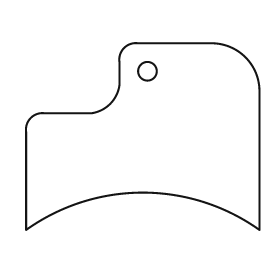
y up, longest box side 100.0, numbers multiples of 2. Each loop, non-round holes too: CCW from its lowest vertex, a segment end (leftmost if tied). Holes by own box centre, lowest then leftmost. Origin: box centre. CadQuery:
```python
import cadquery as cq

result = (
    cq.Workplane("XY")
    .moveTo(-50.0, -40.0)
    .threePointArc((0.0, -24.0), (50.0, -40.0))
    .lineTo(50.0, 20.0)
    .threePointArc((44.0, 34.0), (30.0, 40.0))
    .lineTo(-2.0, 40.0)
    .threePointArc((-8.0, 38.0), (-10.0, 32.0))
    .lineTo(-10.0, 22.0)
    .threePointArc((-14.0, 14.0), (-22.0, 10.0))
    .lineTo(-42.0, 10.0)
    .threePointArc((-48.0, 8.0), (-50.0, 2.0))
    .close()
    .moveTo(2.0, 28.0)
    .circle(4.0)
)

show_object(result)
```